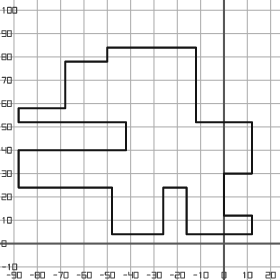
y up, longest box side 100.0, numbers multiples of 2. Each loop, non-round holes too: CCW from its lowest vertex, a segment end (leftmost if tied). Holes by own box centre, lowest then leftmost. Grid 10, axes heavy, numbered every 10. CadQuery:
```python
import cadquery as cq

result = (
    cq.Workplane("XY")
    .moveTo(-48.0, 4.0)
    .lineTo(-26.0, 4.0)
    .lineTo(-26.0, 24.0)
    .lineTo(-16.0, 24.0)
    .lineTo(-16.0, 4.0)
    .lineTo(12.0, 4.0)
    .lineTo(12.0, 12.0)
    .lineTo(0.0, 12.0)
    .lineTo(0.0, 30.0)
    .lineTo(12.0, 30.0)
    .lineTo(12.0, 52.0)
    .lineTo(-12.0, 52.0)
    .lineTo(-12.0, 84.0)
    .lineTo(-50.0, 84.0)
    .lineTo(-50.0, 78.0)
    .lineTo(-68.0, 78.0)
    .lineTo(-68.0, 58.0)
    .lineTo(-88.0, 58.0)
    .lineTo(-88.0, 52.0)
    .lineTo(-42.0, 52.0)
    .lineTo(-42.0, 40.0)
    .lineTo(-88.0, 40.0)
    .lineTo(-88.0, 24.0)
    .lineTo(-48.0, 24.0)
    .close()
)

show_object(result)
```